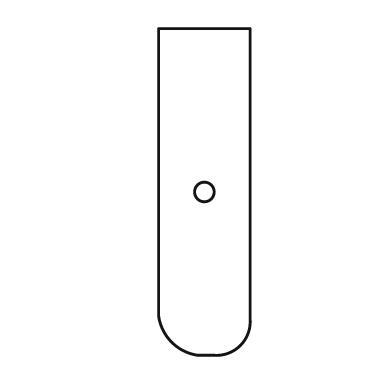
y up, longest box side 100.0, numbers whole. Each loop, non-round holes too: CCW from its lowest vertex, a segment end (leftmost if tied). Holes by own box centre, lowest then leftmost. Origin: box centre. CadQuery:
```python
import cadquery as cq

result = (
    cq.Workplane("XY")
    .moveTo(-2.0, -50.0)
    .lineTo(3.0, -50.0)
    .threePointArc((11.0, -47.0), (14.0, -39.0))
    .lineTo(14.0, 50.0)
    .lineTo(-14.0, 50.0)
    .lineTo(-14.0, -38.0)
    .threePointArc((-10.0, -46.0), (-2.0, -50.0))
    .close()
    .moveTo(0.0, 0.0)
    .circle(3.0)
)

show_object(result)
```